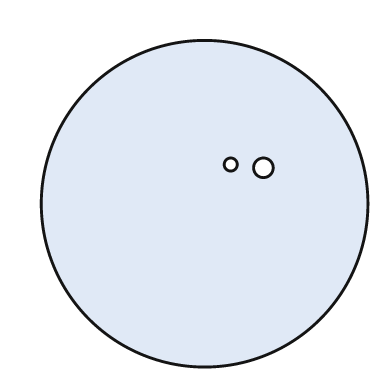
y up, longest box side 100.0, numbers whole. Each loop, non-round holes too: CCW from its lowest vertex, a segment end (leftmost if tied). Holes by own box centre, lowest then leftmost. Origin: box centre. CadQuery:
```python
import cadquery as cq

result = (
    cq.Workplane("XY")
    .moveTo(0.0, 0.0)
    .circle(50.0)
    .moveTo(18.0, 11.0)
    .circle(3.0)
    .moveTo(8.0, 12.0)
    .circle(2.0)
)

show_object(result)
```